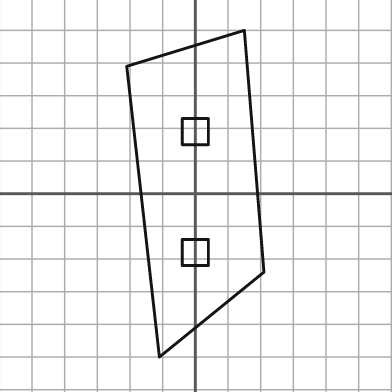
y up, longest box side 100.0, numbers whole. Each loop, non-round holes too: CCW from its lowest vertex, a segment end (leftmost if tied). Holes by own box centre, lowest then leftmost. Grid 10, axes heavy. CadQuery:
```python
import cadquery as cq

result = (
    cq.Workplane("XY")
    .moveTo(-11.0, -50.0)
    .lineTo(21.0, -24.0)
    .lineTo(15.0, 50.0)
    .lineTo(-21.0, 39.0)
    .close()
    .moveTo(-4.0, -22.0)
    .lineTo(4.0, -22.0)
    .lineTo(4.0, -14.0)
    .lineTo(-4.0, -14.0)
    .close()
    .moveTo(-4.0, 15.0)
    .lineTo(4.0, 15.0)
    .lineTo(4.0, 23.0)
    .lineTo(-4.0, 23.0)
    .close()
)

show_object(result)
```